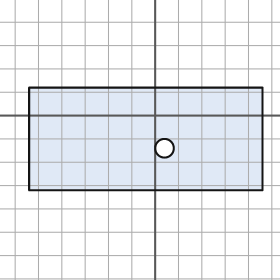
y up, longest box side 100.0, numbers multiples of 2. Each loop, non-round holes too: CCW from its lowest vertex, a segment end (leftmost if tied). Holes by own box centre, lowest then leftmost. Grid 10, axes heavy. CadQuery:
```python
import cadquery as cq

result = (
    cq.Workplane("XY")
    .moveTo(-54.0, -32.0)
    .lineTo(46.0, -32.0)
    .lineTo(46.0, 12.0)
    .lineTo(-54.0, 12.0)
    .close()
    .moveTo(4.0, -14.0)
    .circle(4.0)
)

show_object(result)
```